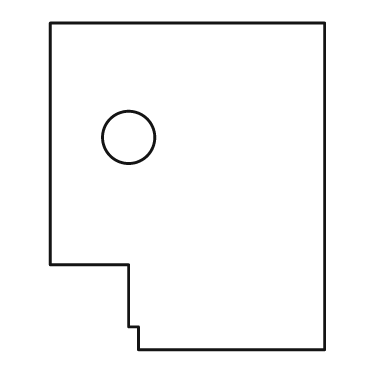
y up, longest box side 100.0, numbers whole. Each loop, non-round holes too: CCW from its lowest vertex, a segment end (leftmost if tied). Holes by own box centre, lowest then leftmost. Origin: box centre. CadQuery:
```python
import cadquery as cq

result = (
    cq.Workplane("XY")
    .moveTo(-15.0, -50.0)
    .lineTo(42.0, -50.0)
    .lineTo(42.0, 50.0)
    .lineTo(-42.0, 50.0)
    .lineTo(-42.0, -24.0)
    .lineTo(-18.0, -24.0)
    .lineTo(-18.0, -43.0)
    .lineTo(-15.0, -43.0)
    .close()
    .moveTo(-18.0, 15.0)
    .circle(8.0)
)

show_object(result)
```